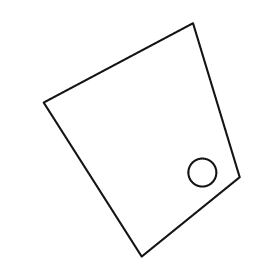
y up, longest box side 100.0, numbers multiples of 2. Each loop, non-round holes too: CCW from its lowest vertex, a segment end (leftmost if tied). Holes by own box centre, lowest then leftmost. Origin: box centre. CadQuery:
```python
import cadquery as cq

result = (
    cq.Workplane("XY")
    .moveTo(0.0, -50.0)
    .lineTo(42.0, -16.0)
    .lineTo(22.0, 50.0)
    .lineTo(-42.0, 16.0)
    .close()
    .moveTo(26.0, -14.0)
    .circle(6.0)
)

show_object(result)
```